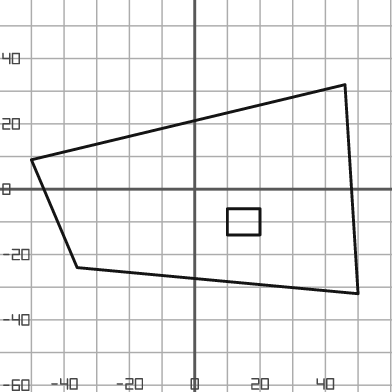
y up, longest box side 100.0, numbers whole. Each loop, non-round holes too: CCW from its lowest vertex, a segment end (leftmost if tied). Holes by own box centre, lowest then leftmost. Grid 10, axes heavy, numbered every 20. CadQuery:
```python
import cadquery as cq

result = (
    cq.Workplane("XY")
    .moveTo(50.0, -32.0)
    .lineTo(46.0, 32.0)
    .lineTo(-50.0, 9.0)
    .lineTo(-36.0, -24.0)
    .close()
    .moveTo(10.0, -14.0)
    .lineTo(20.0, -14.0)
    .lineTo(20.0, -6.0)
    .lineTo(10.0, -6.0)
    .close()
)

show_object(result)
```